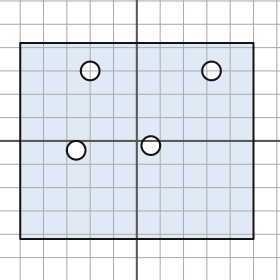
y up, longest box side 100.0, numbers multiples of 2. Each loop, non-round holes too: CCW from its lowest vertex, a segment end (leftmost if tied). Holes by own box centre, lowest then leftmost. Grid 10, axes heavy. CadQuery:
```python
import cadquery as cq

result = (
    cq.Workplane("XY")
    .moveTo(-50.0, -42.0)
    .lineTo(50.0, -42.0)
    .lineTo(50.0, 42.0)
    .lineTo(-50.0, 42.0)
    .close()
    .moveTo(-26.0, -4.0)
    .circle(4.0)
    .moveTo(6.0, -2.0)
    .circle(4.0)
    .moveTo(-20.0, 30.0)
    .circle(4.0)
    .moveTo(32.0, 30.0)
    .circle(4.0)
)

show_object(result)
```